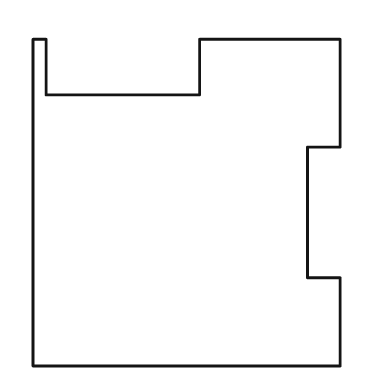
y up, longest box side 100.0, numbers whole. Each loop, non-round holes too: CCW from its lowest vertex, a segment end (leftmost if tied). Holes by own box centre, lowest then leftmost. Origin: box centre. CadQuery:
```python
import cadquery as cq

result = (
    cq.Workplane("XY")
    .moveTo(-47.0, -50.0)
    .lineTo(47.0, -50.0)
    .lineTo(47.0, -23.0)
    .lineTo(37.0, -23.0)
    .lineTo(37.0, 17.0)
    .lineTo(47.0, 17.0)
    .lineTo(47.0, 50.0)
    .lineTo(4.0, 50.0)
    .lineTo(4.0, 33.0)
    .lineTo(-43.0, 33.0)
    .lineTo(-43.0, 50.0)
    .lineTo(-47.0, 50.0)
    .close()
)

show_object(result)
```